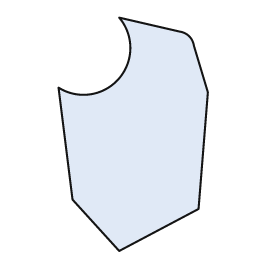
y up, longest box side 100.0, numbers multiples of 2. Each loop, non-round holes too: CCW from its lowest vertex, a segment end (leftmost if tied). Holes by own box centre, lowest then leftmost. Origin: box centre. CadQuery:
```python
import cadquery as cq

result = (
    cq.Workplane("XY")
    .moveTo(-6.0, -50.0)
    .lineTo(28.0, -32.0)
    .lineTo(32.0, 18.0)
    .lineTo(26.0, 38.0)
    .threePointArc((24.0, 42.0), (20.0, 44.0))
    .lineTo(-6.0, 50.0)
    .threePointArc((-6.0, 24.0), (-32.0, 20.0))
    .lineTo(-26.0, -28.0)
    .close()
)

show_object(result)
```